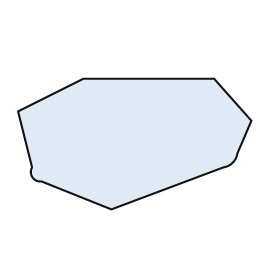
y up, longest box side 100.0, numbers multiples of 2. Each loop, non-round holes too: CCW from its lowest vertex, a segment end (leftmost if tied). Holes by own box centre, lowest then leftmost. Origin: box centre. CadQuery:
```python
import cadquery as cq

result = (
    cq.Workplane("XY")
    .moveTo(-10.0, -28.0)
    .lineTo(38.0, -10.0)
    .threePointArc((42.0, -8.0), (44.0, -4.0))
    .lineTo(50.0, 10.0)
    .lineTo(34.0, 28.0)
    .lineTo(-22.0, 28.0)
    .lineTo(-50.0, 14.0)
    .lineTo(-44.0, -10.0)
    .threePointArc((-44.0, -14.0), (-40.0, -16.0))
    .close()
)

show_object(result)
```